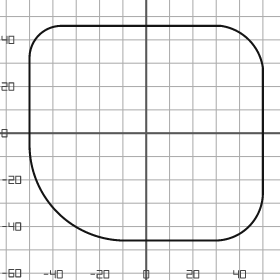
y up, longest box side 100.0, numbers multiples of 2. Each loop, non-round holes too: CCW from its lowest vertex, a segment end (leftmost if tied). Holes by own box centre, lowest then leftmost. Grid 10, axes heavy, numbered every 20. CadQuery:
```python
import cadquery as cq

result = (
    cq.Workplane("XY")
    .moveTo(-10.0, -46.0)
    .lineTo(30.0, -46.0)
    .threePointArc((44.0, -40.0), (50.0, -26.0))
    .lineTo(50.0, 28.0)
    .threePointArc((44.0, 40.0), (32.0, 46.0))
    .lineTo(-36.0, 46.0)
    .threePointArc((-46.0, 42.0), (-50.0, 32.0))
    .lineTo(-50.0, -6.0)
    .threePointArc((-38.0, -34.0), (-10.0, -46.0))
    .close()
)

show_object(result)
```